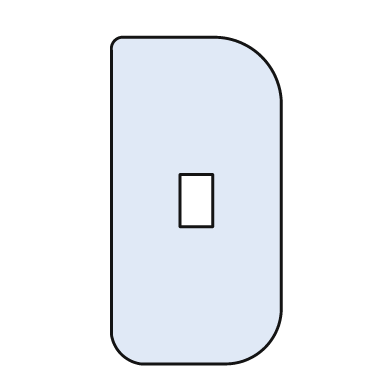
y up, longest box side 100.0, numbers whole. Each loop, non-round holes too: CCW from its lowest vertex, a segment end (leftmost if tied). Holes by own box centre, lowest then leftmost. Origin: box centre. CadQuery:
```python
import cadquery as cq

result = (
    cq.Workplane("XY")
    .moveTo(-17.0, -50.0)
    .lineTo(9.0, -50.0)
    .threePointArc((21.0, -45.0), (26.0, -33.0))
    .lineTo(26.0, 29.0)
    .threePointArc((20.0, 44.0), (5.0, 50.0))
    .lineTo(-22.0, 50.0)
    .threePointArc((-25.0, 49.0), (-26.0, 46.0))
    .lineTo(-26.0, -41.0)
    .threePointArc((-23.0, -47.0), (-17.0, -50.0))
    .close()
    .moveTo(-5.0, -8.0)
    .lineTo(5.0, -8.0)
    .lineTo(5.0, 8.0)
    .lineTo(-5.0, 8.0)
    .close()
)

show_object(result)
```